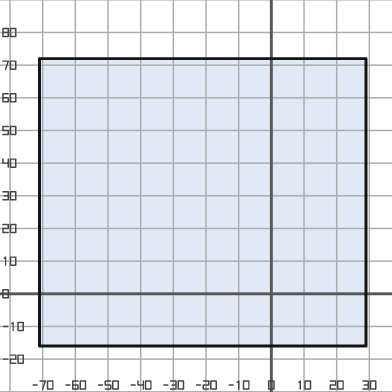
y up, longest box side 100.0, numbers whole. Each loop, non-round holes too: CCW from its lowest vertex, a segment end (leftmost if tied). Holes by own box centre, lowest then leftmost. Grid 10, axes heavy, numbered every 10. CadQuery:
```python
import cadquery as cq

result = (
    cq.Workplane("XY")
    .moveTo(-71.0, -16.0)
    .lineTo(29.0, -16.0)
    .lineTo(29.0, 72.0)
    .lineTo(-71.0, 72.0)
    .close()
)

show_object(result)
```